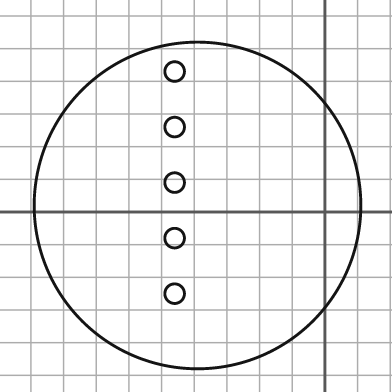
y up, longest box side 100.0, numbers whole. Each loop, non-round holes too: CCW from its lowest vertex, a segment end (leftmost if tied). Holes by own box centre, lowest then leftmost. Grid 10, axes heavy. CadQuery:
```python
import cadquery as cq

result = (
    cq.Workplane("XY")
    .moveTo(-39.0, 2.0)
    .circle(50.0)
    .moveTo(-46.0, -25.0)
    .circle(3.0)
    .moveTo(-46.0, -8.0)
    .circle(3.0)
    .moveTo(-46.0, 9.0)
    .circle(3.0)
    .moveTo(-46.0, 26.0)
    .circle(3.0)
    .moveTo(-46.0, 43.0)
    .circle(3.0)
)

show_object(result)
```